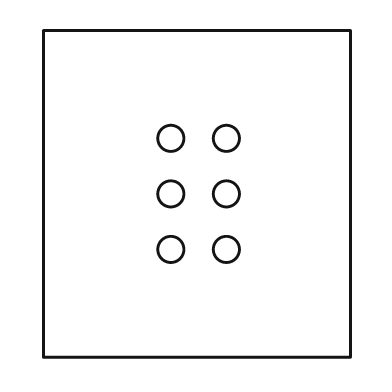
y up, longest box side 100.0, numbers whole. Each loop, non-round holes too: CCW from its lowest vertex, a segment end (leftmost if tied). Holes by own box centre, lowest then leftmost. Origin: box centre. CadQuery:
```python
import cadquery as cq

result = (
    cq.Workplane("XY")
    .moveTo(-47.0, -50.0)
    .lineTo(47.0, -50.0)
    .lineTo(47.0, 50.0)
    .lineTo(-47.0, 50.0)
    .close()
    .moveTo(-8.0, -17.0)
    .circle(4.0)
    .moveTo(9.0, -17.0)
    .circle(4.0)
    .moveTo(-8.0, 0.0)
    .circle(4.0)
    .moveTo(9.0, 0.0)
    .circle(4.0)
    .moveTo(-8.0, 17.0)
    .circle(4.0)
    .moveTo(9.0, 17.0)
    .circle(4.0)
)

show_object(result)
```